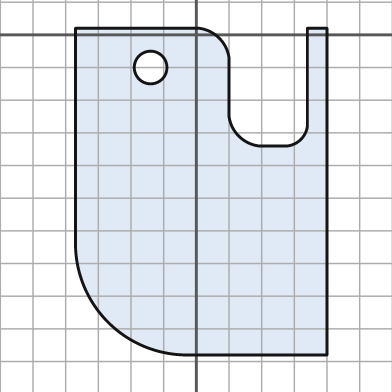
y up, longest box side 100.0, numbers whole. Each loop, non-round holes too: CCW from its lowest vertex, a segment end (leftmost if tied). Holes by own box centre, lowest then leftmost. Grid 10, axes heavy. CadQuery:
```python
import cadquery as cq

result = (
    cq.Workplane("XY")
    .moveTo(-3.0, -98.0)
    .lineTo(40.0, -98.0)
    .lineTo(40.0, 2.0)
    .lineTo(34.0, 2.0)
    .lineTo(34.0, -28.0)
    .threePointArc((32.0, -32.0), (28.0, -34.0))
    .lineTo(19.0, -34.0)
    .threePointArc((13.0, -31.0), (10.0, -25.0))
    .lineTo(10.0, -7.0)
    .threePointArc((7.0, -1.0), (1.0, 2.0))
    .lineTo(-37.0, 2.0)
    .lineTo(-37.0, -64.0)
    .threePointArc((-27.0, -88.0), (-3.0, -98.0))
    .close()
    .moveTo(-14.0, -10.0)
    .circle(5.0)
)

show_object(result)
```